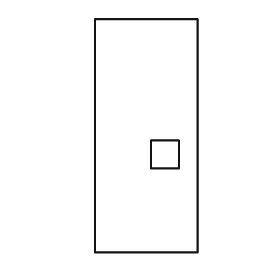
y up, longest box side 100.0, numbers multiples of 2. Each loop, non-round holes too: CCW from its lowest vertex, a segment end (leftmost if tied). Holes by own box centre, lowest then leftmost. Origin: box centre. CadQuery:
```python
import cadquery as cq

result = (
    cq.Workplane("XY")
    .moveTo(-22.0, -50.0)
    .lineTo(22.0, -50.0)
    .lineTo(22.0, 50.0)
    .lineTo(-22.0, 50.0)
    .close()
    .moveTo(2.0, -14.0)
    .lineTo(14.0, -14.0)
    .lineTo(14.0, -2.0)
    .lineTo(2.0, -2.0)
    .close()
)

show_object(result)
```